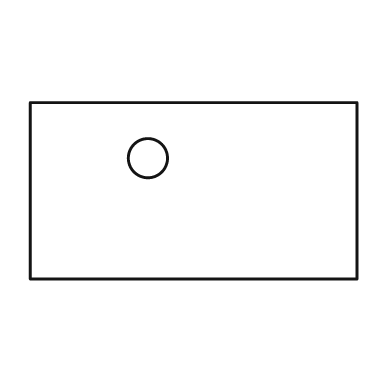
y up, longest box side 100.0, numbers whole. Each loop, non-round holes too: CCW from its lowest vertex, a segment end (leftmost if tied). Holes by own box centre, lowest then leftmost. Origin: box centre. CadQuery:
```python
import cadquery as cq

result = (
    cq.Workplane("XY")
    .moveTo(-50.0, -27.0)
    .lineTo(50.0, -27.0)
    .lineTo(50.0, 27.0)
    .lineTo(-50.0, 27.0)
    .close()
    .moveTo(-14.0, 10.0)
    .circle(6.0)
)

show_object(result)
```